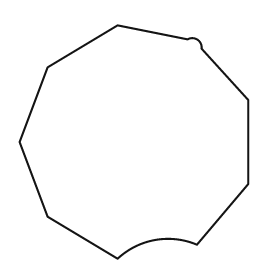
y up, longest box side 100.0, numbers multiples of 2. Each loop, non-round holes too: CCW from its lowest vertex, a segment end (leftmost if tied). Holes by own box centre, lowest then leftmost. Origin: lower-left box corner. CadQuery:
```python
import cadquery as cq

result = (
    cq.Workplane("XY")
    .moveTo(42.0, 0.0)
    .threePointArc((58.0, 8.0), (76.0, 6.0))
    .lineTo(98.0, 32.0)
    .lineTo(98.0, 68.0)
    .lineTo(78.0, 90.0)
    .threePointArc((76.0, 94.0), (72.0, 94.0))
    .lineTo(42.0, 100.0)
    .lineTo(12.0, 82.0)
    .lineTo(0.0, 50.0)
    .lineTo(12.0, 18.0)
    .close()
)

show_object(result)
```